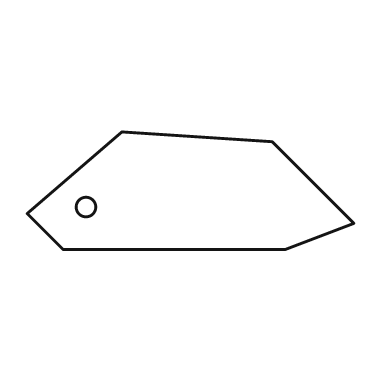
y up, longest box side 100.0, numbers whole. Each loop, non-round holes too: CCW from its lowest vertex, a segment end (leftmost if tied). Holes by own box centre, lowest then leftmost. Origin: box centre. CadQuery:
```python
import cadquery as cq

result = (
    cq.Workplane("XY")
    .moveTo(-39.0, -18.0)
    .lineTo(29.0, -18.0)
    .lineTo(50.0, -10.0)
    .lineTo(25.0, 15.0)
    .lineTo(-21.0, 18.0)
    .lineTo(-50.0, -7.0)
    .close()
    .moveTo(-32.0, -5.0)
    .circle(3.0)
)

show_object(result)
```